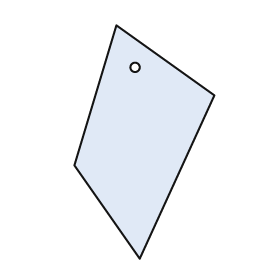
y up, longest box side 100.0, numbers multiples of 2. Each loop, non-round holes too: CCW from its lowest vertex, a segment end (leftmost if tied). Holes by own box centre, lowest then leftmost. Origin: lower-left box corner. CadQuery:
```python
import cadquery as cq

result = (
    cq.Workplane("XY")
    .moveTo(28.0, 0.0)
    .lineTo(60.0, 70.0)
    .lineTo(18.0, 100.0)
    .lineTo(0.0, 40.0)
    .close()
    .moveTo(26.0, 82.0)
    .circle(2.0)
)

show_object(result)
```